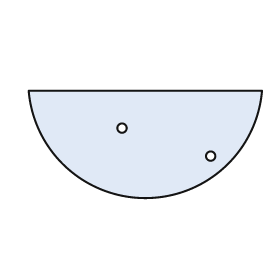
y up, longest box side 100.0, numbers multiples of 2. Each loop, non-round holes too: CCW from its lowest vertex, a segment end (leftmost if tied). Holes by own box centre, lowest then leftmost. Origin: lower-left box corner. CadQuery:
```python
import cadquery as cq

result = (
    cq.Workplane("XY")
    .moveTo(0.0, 46.0)
    .threePointArc((50.0, 0.0), (100.0, 46.0))
    .close()
    .moveTo(78.0, 18.0)
    .circle(2.0)
    .moveTo(40.0, 30.0)
    .circle(2.0)
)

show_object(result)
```